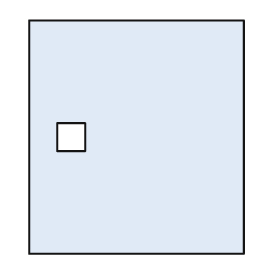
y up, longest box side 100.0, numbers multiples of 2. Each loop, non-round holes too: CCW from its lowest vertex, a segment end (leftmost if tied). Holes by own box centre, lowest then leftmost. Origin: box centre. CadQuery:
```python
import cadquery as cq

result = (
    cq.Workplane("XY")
    .moveTo(-46.0, -50.0)
    .lineTo(46.0, -50.0)
    .lineTo(46.0, 50.0)
    .lineTo(-46.0, 50.0)
    .close()
    .moveTo(-34.0, -6.0)
    .lineTo(-22.0, -6.0)
    .lineTo(-22.0, 6.0)
    .lineTo(-34.0, 6.0)
    .close()
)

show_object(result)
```